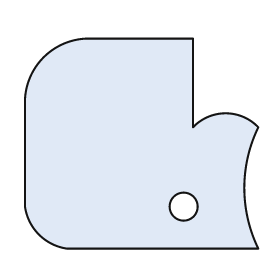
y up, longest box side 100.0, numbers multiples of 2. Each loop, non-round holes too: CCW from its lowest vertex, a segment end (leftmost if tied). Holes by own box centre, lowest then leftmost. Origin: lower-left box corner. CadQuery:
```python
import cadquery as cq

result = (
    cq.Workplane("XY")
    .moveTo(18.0, 0.0)
    .lineTo(100.0, 0.0)
    .threePointArc((94.0, 26.0), (100.0, 52.0))
    .threePointArc((86.0, 58.0), (72.0, 52.0))
    .lineTo(72.0, 90.0)
    .lineTo(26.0, 90.0)
    .threePointArc((8.0, 82.0), (0.0, 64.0))
    .lineTo(0.0, 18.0)
    .threePointArc((6.0, 6.0), (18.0, 0.0))
    .close()
    .moveTo(68.0, 18.0)
    .circle(6.0)
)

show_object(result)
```